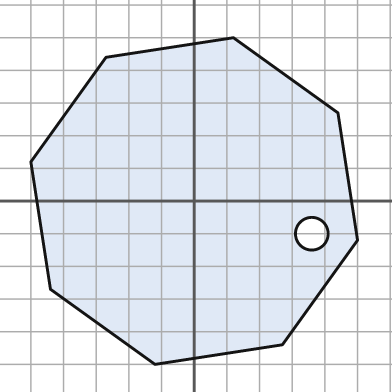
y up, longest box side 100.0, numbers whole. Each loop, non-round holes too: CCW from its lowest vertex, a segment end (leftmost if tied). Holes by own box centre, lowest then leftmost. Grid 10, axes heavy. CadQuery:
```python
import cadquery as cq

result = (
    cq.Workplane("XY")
    .moveTo(-12.0, -50.0)
    .lineTo(27.0, -44.0)
    .lineTo(50.0, -12.0)
    .lineTo(44.0, 27.0)
    .lineTo(12.0, 50.0)
    .lineTo(-27.0, 44.0)
    .lineTo(-50.0, 12.0)
    .lineTo(-44.0, -27.0)
    .close()
    .moveTo(36.0, -10.0)
    .circle(5.0)
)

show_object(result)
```